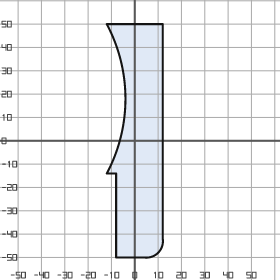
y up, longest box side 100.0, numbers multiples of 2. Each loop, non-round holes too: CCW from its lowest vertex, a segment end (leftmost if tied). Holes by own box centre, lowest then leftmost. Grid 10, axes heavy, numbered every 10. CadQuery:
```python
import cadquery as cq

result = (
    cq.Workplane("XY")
    .moveTo(-8.0, -50.0)
    .lineTo(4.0, -50.0)
    .threePointArc((10.0, -48.0), (12.0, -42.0))
    .lineTo(12.0, 50.0)
    .lineTo(-12.0, 50.0)
    .threePointArc((-4.0, 18.0), (-12.0, -14.0))
    .lineTo(-8.0, -14.0)
    .close()
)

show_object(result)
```